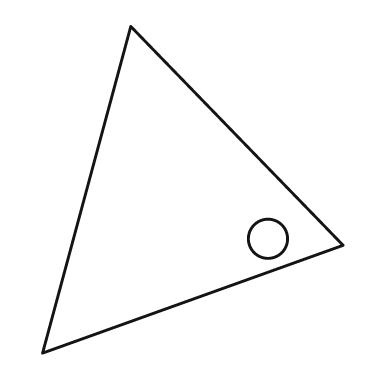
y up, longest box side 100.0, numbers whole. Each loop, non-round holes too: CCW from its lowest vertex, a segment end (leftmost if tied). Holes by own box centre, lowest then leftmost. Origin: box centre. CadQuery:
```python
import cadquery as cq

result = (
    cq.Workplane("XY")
    .moveTo(-46.0, -50.0)
    .lineTo(46.0, -17.0)
    .lineTo(-19.0, 50.0)
    .close()
    .moveTo(23.0, -15.0)
    .circle(6.0)
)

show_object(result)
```